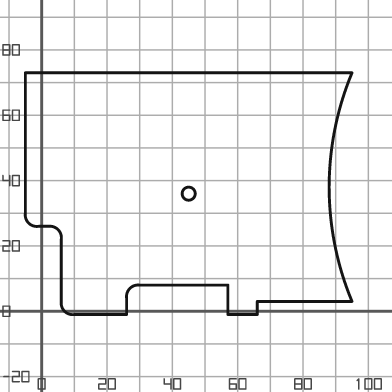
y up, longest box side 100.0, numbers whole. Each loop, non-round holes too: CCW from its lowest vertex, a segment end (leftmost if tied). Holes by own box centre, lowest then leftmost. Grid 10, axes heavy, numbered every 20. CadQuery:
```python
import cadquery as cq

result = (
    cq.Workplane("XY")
    .moveTo(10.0, -1.0)
    .lineTo(26.0, -1.0)
    .lineTo(26.0, 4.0)
    .threePointArc((27.0, 7.0), (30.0, 8.0))
    .lineTo(57.0, 8.0)
    .lineTo(57.0, -1.0)
    .lineTo(66.0, -1.0)
    .lineTo(66.0, 3.0)
    .lineTo(95.0, 3.0)
    .threePointArc((88.0, 38.0), (95.0, 73.0))
    .lineTo(-5.0, 73.0)
    .lineTo(-5.0, 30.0)
    .threePointArc((-4.0, 27.0), (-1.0, 26.0))
    .lineTo(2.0, 26.0)
    .threePointArc((5.0, 25.0), (6.0, 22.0))
    .lineTo(6.0, 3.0)
    .threePointArc((7.0, 0.0), (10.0, -1.0))
    .close()
    .moveTo(45.0, 36.0)
    .circle(2.0)
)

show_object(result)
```